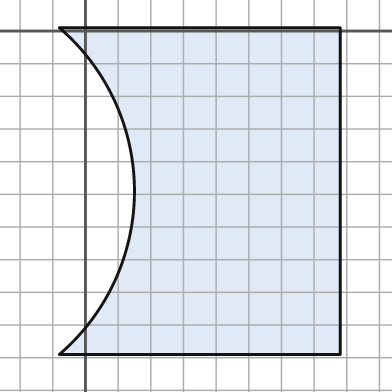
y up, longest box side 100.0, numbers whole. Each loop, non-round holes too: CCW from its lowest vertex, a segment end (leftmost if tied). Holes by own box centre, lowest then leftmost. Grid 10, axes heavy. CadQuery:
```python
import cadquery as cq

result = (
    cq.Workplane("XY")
    .moveTo(-8.0, -99.0)
    .lineTo(78.0, -99.0)
    .lineTo(78.0, 1.0)
    .lineTo(-8.0, 1.0)
    .threePointArc((15.0, -49.0), (-8.0, -99.0))
    .close()
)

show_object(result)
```